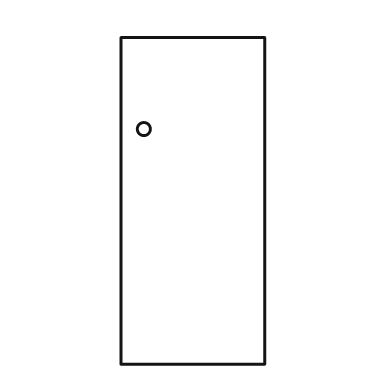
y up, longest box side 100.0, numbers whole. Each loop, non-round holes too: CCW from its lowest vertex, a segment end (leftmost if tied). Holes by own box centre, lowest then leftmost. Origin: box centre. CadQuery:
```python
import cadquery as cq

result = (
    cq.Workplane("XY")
    .moveTo(-22.0, -50.0)
    .lineTo(22.0, -50.0)
    .lineTo(22.0, 50.0)
    .lineTo(-22.0, 50.0)
    .close()
    .moveTo(-15.0, 22.0)
    .circle(2.0)
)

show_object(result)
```